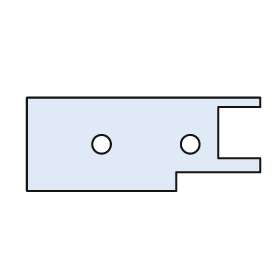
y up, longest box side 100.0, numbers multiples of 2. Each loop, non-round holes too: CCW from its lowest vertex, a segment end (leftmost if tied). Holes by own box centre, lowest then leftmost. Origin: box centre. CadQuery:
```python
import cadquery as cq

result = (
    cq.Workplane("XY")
    .moveTo(-50.0, -20.0)
    .lineTo(14.0, -20.0)
    .lineTo(14.0, -12.0)
    .lineTo(50.0, -12.0)
    .lineTo(50.0, -6.0)
    .lineTo(32.0, -6.0)
    .lineTo(32.0, 16.0)
    .lineTo(50.0, 16.0)
    .lineTo(50.0, 20.0)
    .lineTo(-50.0, 20.0)
    .close()
    .moveTo(-18.0, 0.0)
    .circle(4.0)
    .moveTo(20.0, 0.0)
    .circle(4.0)
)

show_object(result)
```